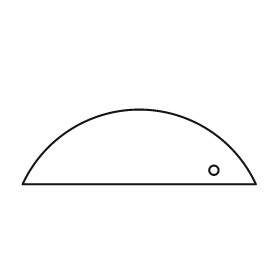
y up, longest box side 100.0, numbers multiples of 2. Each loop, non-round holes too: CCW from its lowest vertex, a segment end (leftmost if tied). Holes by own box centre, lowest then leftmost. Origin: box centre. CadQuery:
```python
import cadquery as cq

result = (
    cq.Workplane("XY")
    .moveTo(-50.0, -16.0)
    .lineTo(50.0, -16.0)
    .threePointArc((0.0, 16.0), (-50.0, -16.0))
    .close()
    .moveTo(32.0, -10.0)
    .circle(2.0)
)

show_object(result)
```